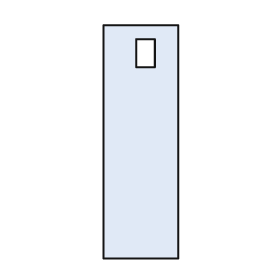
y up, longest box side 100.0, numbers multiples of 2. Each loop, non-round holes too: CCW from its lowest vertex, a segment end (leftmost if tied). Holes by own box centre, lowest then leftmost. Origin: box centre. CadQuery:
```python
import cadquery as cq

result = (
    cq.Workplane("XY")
    .moveTo(-16.0, -50.0)
    .lineTo(16.0, -50.0)
    .lineTo(16.0, 50.0)
    .lineTo(-16.0, 50.0)
    .close()
    .moveTo(-2.0, 32.0)
    .lineTo(6.0, 32.0)
    .lineTo(6.0, 44.0)
    .lineTo(-2.0, 44.0)
    .close()
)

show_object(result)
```